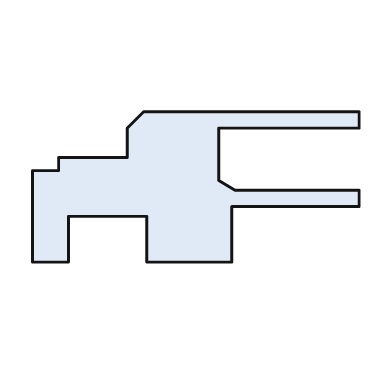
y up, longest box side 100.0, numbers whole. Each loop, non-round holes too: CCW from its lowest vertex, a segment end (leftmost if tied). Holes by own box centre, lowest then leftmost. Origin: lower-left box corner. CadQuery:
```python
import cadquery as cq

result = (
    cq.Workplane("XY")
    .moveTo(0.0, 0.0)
    .lineTo(11.0, 0.0)
    .lineTo(11.0, 14.0)
    .lineTo(35.0, 14.0)
    .lineTo(35.0, 0.0)
    .lineTo(61.0, 0.0)
    .lineTo(61.0, 17.0)
    .lineTo(100.0, 17.0)
    .lineTo(100.0, 22.0)
    .lineTo(62.0, 22.0)
    .lineTo(57.0, 25.0)
    .lineTo(57.0, 41.0)
    .lineTo(100.0, 41.0)
    .lineTo(100.0, 46.0)
    .lineTo(34.0, 46.0)
    .lineTo(29.0, 41.0)
    .lineTo(29.0, 32.0)
    .lineTo(8.0, 32.0)
    .lineTo(8.0, 28.0)
    .lineTo(0.0, 28.0)
    .close()
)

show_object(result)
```